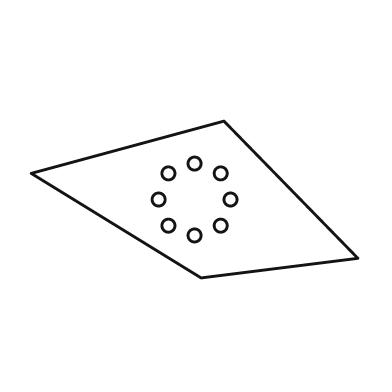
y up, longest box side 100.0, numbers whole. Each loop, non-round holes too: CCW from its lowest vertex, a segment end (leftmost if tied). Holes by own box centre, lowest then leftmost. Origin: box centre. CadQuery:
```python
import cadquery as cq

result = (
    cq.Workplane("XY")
    .moveTo(2.0, -24.0)
    .lineTo(50.0, -18.0)
    .lineTo(9.0, 24.0)
    .lineTo(-50.0, 8.0)
    .close()
    .moveTo(0.0, -11.0)
    .circle(2.0)
    .moveTo(-8.0, -8.0)
    .circle(2.0)
    .moveTo(8.0, -8.0)
    .circle(2.0)
    .moveTo(-11.0, 0.0)
    .circle(2.0)
    .moveTo(11.0, 0.0)
    .circle(2.0)
    .moveTo(-8.0, 8.0)
    .circle(2.0)
    .moveTo(8.0, 8.0)
    .circle(2.0)
    .moveTo(0.0, 11.0)
    .circle(2.0)
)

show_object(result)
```